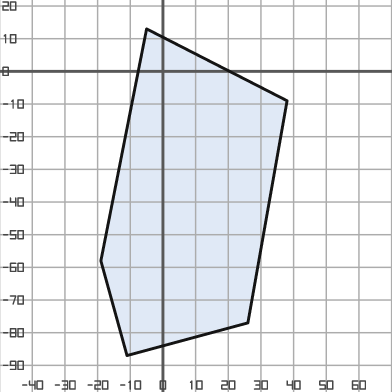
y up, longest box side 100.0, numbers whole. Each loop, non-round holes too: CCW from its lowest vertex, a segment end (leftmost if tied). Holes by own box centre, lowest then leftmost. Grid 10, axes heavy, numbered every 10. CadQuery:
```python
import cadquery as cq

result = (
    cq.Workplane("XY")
    .moveTo(-11.0, -87.0)
    .lineTo(26.0, -77.0)
    .lineTo(38.0, -9.0)
    .lineTo(-5.0, 13.0)
    .lineTo(-19.0, -58.0)
    .close()
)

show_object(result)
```